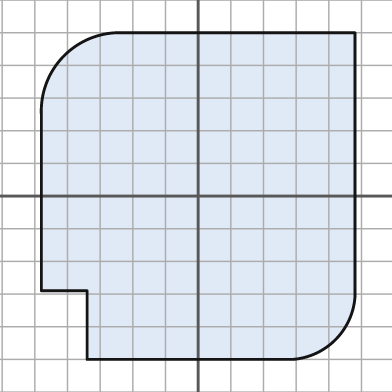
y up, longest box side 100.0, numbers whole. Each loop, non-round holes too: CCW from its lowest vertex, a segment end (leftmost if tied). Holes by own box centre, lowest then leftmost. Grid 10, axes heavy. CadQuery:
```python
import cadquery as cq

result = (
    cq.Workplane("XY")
    .moveTo(-34.0, -50.0)
    .lineTo(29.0, -50.0)
    .threePointArc((42.0, -44.0), (48.0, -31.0))
    .lineTo(48.0, 50.0)
    .lineTo(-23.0, 50.0)
    .threePointArc((-41.0, 43.0), (-48.0, 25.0))
    .lineTo(-48.0, -29.0)
    .lineTo(-34.0, -29.0)
    .close()
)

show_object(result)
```